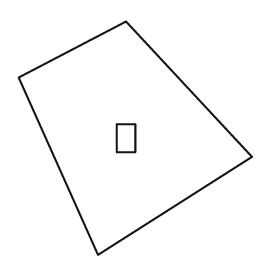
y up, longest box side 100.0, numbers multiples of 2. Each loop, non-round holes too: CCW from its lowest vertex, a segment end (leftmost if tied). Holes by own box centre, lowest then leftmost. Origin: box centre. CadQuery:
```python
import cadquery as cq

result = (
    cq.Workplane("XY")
    .moveTo(-16.0, -50.0)
    .lineTo(50.0, -8.0)
    .lineTo(-4.0, 50.0)
    .lineTo(-50.0, 26.0)
    .close()
    .moveTo(-8.0, -6.0)
    .lineTo(0.0, -6.0)
    .lineTo(0.0, 6.0)
    .lineTo(-8.0, 6.0)
    .close()
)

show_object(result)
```